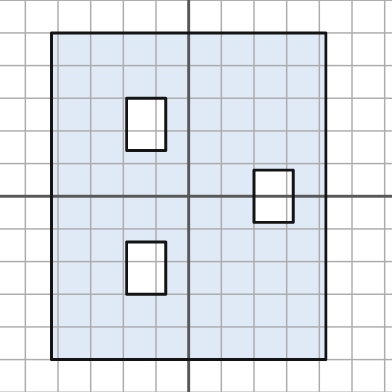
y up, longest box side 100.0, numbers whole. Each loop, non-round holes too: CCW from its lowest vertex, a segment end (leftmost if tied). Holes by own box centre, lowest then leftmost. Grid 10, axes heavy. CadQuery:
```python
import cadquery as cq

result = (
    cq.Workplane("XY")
    .moveTo(-42.0, -50.0)
    .lineTo(42.0, -50.0)
    .lineTo(42.0, 50.0)
    .lineTo(-42.0, 50.0)
    .close()
    .moveTo(-19.0, -30.0)
    .lineTo(-7.0, -30.0)
    .lineTo(-7.0, -14.0)
    .lineTo(-19.0, -14.0)
    .close()
    .moveTo(20.0, -8.0)
    .lineTo(32.0, -8.0)
    .lineTo(32.0, 8.0)
    .lineTo(20.0, 8.0)
    .close()
    .moveTo(-19.0, 14.0)
    .lineTo(-7.0, 14.0)
    .lineTo(-7.0, 30.0)
    .lineTo(-19.0, 30.0)
    .close()
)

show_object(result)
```